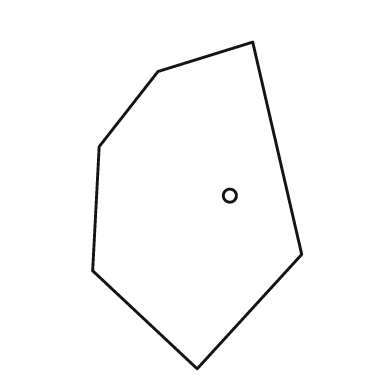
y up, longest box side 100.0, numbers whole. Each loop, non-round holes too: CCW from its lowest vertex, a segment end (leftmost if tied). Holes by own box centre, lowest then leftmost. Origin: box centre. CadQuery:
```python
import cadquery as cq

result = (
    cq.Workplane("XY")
    .moveTo(0.0, -50.0)
    .lineTo(32.0, -15.0)
    .lineTo(17.0, 50.0)
    .lineTo(-12.0, 41.0)
    .lineTo(-30.0, 18.0)
    .lineTo(-32.0, -20.0)
    .close()
    .moveTo(10.0, 3.0)
    .circle(2.0)
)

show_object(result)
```